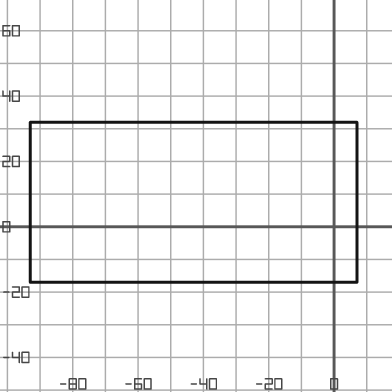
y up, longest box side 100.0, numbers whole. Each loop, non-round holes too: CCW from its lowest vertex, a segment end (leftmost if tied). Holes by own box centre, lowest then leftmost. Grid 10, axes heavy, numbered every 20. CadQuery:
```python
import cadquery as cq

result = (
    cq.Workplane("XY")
    .moveTo(-93.0, -17.0)
    .lineTo(7.0, -17.0)
    .lineTo(7.0, 32.0)
    .lineTo(-93.0, 32.0)
    .close()
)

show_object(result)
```